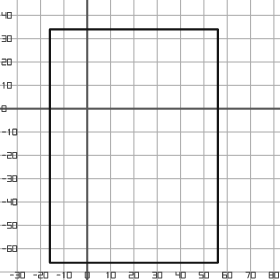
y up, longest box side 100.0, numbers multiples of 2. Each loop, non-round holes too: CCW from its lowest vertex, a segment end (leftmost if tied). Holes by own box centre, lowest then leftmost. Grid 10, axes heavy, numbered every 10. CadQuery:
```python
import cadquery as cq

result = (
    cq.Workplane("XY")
    .moveTo(-16.0, -66.0)
    .lineTo(56.0, -66.0)
    .lineTo(56.0, 34.0)
    .lineTo(-16.0, 34.0)
    .close()
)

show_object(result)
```